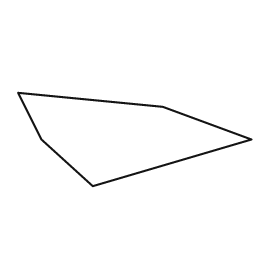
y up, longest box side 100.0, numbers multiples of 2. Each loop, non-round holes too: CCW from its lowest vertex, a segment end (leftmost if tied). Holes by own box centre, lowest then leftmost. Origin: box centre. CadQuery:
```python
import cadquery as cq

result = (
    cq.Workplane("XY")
    .moveTo(-18.0, -20.0)
    .lineTo(50.0, 0.0)
    .lineTo(12.0, 14.0)
    .lineTo(-50.0, 20.0)
    .lineTo(-40.0, 0.0)
    .close()
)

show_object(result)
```